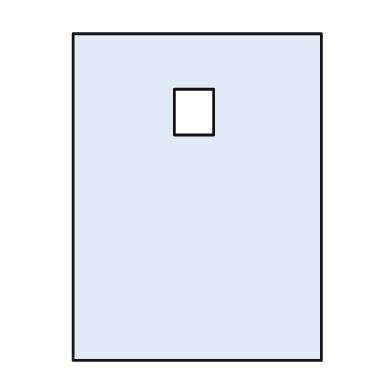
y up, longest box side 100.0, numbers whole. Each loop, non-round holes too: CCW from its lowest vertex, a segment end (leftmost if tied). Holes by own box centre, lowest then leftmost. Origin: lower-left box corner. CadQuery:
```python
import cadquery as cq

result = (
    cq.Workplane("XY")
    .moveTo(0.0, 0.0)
    .lineTo(76.0, 0.0)
    .lineTo(76.0, 100.0)
    .lineTo(0.0, 100.0)
    .close()
    .moveTo(31.0, 69.0)
    .lineTo(43.0, 69.0)
    .lineTo(43.0, 83.0)
    .lineTo(31.0, 83.0)
    .close()
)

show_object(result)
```